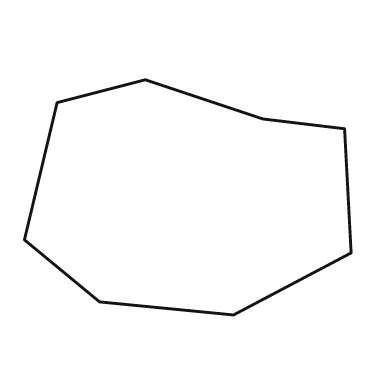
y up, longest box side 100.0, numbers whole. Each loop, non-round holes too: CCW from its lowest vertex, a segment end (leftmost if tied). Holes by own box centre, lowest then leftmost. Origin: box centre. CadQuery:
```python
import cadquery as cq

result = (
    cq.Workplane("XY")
    .moveTo(14.0, -36.0)
    .lineTo(50.0, -17.0)
    .lineTo(48.0, 21.0)
    .lineTo(23.0, 24.0)
    .lineTo(-13.0, 36.0)
    .lineTo(-40.0, 29.0)
    .lineTo(-50.0, -13.0)
    .lineTo(-27.0, -32.0)
    .close()
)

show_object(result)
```